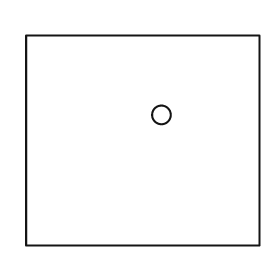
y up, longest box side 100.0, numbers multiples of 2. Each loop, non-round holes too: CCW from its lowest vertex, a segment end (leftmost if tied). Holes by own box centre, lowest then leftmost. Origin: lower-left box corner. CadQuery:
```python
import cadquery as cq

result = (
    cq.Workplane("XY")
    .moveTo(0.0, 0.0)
    .lineTo(100.0, 0.0)
    .lineTo(100.0, 90.0)
    .lineTo(0.0, 90.0)
    .close()
    .moveTo(58.0, 56.0)
    .circle(4.0)
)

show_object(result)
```